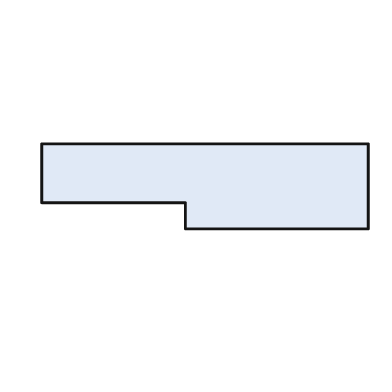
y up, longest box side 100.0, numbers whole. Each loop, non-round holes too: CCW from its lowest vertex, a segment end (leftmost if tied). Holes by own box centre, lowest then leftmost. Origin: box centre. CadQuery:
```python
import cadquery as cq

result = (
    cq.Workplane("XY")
    .moveTo(-6.0, -13.0)
    .lineTo(50.0, -13.0)
    .lineTo(50.0, 13.0)
    .lineTo(-50.0, 13.0)
    .lineTo(-50.0, -5.0)
    .lineTo(-6.0, -5.0)
    .close()
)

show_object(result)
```